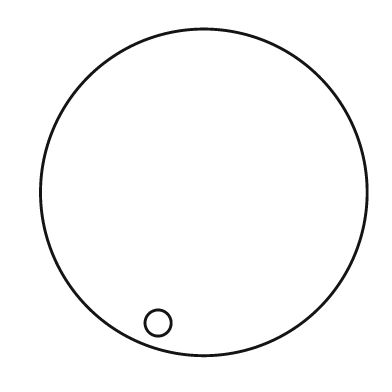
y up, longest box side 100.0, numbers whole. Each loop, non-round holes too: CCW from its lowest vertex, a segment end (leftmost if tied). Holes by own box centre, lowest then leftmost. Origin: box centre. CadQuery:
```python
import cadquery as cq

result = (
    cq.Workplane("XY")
    .moveTo(0.0, 0.0)
    .circle(50.0)
    .moveTo(-14.0, -40.0)
    .circle(4.0)
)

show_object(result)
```